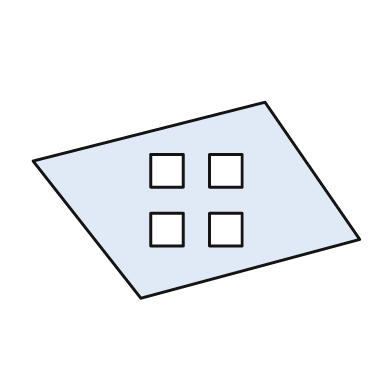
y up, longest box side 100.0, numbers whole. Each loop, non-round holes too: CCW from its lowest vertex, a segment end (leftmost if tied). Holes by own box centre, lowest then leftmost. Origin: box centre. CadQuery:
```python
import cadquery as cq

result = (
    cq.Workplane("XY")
    .moveTo(-17.0, -30.0)
    .lineTo(50.0, -12.0)
    .lineTo(21.0, 30.0)
    .lineTo(-50.0, 12.0)
    .close()
    .moveTo(-14.0, -14.0)
    .lineTo(-4.0, -14.0)
    .lineTo(-4.0, -4.0)
    .lineTo(-14.0, -4.0)
    .close()
    .moveTo(4.0, -14.0)
    .lineTo(14.0, -14.0)
    .lineTo(14.0, -4.0)
    .lineTo(4.0, -4.0)
    .close()
    .moveTo(-14.0, 4.0)
    .lineTo(-4.0, 4.0)
    .lineTo(-4.0, 14.0)
    .lineTo(-14.0, 14.0)
    .close()
    .moveTo(4.0, 4.0)
    .lineTo(14.0, 4.0)
    .lineTo(14.0, 14.0)
    .lineTo(4.0, 14.0)
    .close()
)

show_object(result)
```